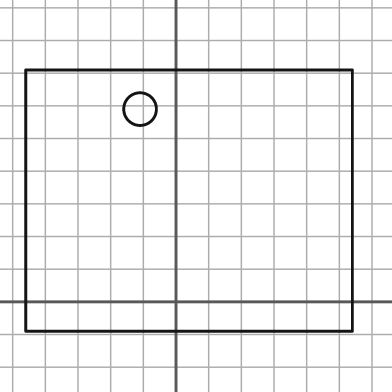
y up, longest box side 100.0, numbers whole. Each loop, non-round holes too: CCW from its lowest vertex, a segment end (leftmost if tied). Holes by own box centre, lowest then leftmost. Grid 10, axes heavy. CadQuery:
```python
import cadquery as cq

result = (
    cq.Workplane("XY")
    .moveTo(-46.0, -9.0)
    .lineTo(54.0, -9.0)
    .lineTo(54.0, 71.0)
    .lineTo(-46.0, 71.0)
    .close()
    .moveTo(-11.0, 59.0)
    .circle(5.0)
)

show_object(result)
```